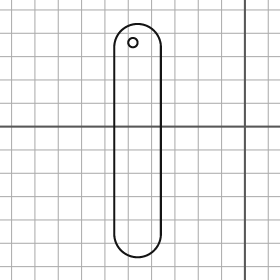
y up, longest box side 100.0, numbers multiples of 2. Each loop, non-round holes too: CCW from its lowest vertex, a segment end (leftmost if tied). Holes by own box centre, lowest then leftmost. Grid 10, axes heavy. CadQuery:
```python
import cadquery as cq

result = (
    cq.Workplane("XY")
    .moveTo(-56.0, -46.0)
    .threePointArc((-46.0, -56.0), (-36.0, -46.0))
    .lineTo(-36.0, 34.0)
    .threePointArc((-46.0, 44.0), (-56.0, 34.0))
    .close()
    .moveTo(-48.0, 36.0)
    .circle(2.0)
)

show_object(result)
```